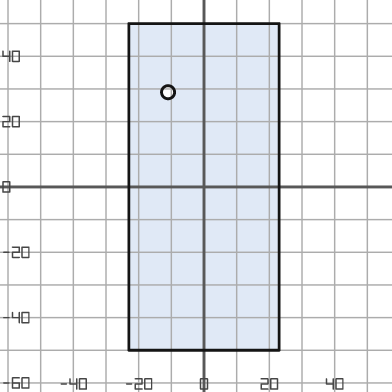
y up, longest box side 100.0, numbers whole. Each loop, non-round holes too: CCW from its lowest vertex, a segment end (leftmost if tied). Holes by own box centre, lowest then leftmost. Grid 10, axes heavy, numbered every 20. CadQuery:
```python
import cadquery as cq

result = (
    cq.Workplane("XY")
    .moveTo(-23.0, -50.0)
    .lineTo(23.0, -50.0)
    .lineTo(23.0, 50.0)
    .lineTo(-23.0, 50.0)
    .close()
    .moveTo(-11.0, 29.0)
    .circle(2.0)
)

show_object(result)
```